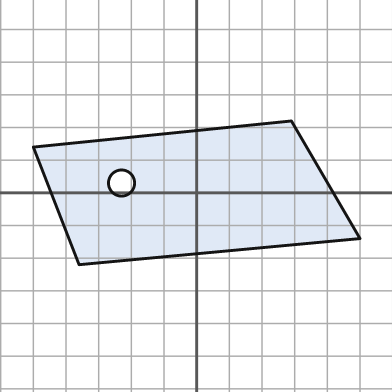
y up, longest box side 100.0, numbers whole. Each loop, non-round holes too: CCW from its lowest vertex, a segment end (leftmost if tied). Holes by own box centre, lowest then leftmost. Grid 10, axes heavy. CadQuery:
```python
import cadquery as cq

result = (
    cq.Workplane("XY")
    .moveTo(-36.0, -22.0)
    .lineTo(50.0, -14.0)
    .lineTo(29.0, 22.0)
    .lineTo(-50.0, 14.0)
    .close()
    .moveTo(-23.0, 3.0)
    .circle(4.0)
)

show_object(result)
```